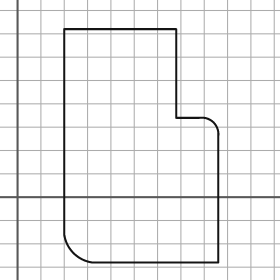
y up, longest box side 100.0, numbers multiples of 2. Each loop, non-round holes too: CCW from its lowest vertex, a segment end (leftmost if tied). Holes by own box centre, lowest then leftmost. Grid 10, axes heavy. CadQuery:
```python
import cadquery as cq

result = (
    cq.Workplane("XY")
    .moveTo(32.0, -28.0)
    .lineTo(86.0, -28.0)
    .lineTo(86.0, 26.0)
    .threePointArc((84.0, 32.0), (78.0, 34.0))
    .lineTo(68.0, 34.0)
    .lineTo(68.0, 72.0)
    .lineTo(20.0, 72.0)
    .lineTo(20.0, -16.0)
    .threePointArc((24.0, -24.0), (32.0, -28.0))
    .close()
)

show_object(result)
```